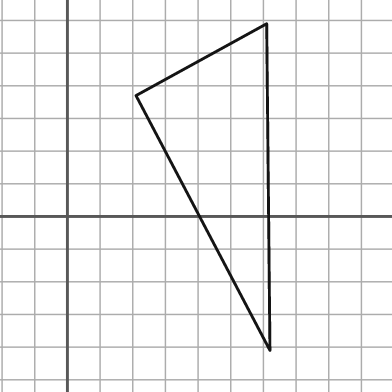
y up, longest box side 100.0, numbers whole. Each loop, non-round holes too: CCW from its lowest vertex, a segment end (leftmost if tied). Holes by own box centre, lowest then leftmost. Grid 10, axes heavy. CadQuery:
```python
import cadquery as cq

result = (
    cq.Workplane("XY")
    .moveTo(62.0, -41.0)
    .lineTo(61.0, 59.0)
    .lineTo(21.0, 37.0)
    .close()
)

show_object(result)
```